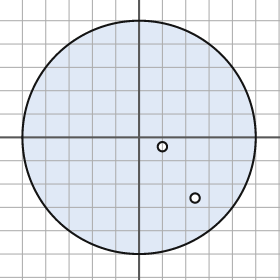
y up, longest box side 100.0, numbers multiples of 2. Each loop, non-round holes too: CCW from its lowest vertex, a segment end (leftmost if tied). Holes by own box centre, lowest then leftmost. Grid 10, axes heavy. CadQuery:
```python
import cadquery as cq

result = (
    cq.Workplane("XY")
    .moveTo(0.0, 0.0)
    .circle(50.0)
    .moveTo(24.0, -26.0)
    .circle(2.0)
    .moveTo(10.0, -4.0)
    .circle(2.0)
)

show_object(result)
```